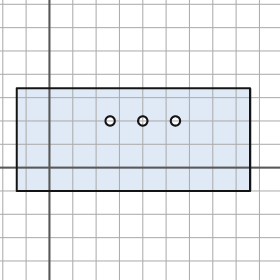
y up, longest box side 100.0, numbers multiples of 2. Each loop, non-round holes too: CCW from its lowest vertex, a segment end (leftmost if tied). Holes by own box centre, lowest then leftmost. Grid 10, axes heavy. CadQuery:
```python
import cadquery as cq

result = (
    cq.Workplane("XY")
    .moveTo(-14.0, -10.0)
    .lineTo(86.0, -10.0)
    .lineTo(86.0, 34.0)
    .lineTo(-14.0, 34.0)
    .close()
    .moveTo(26.0, 20.0)
    .circle(2.0)
    .moveTo(40.0, 20.0)
    .circle(2.0)
    .moveTo(54.0, 20.0)
    .circle(2.0)
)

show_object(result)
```